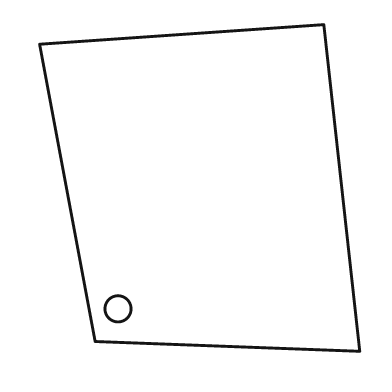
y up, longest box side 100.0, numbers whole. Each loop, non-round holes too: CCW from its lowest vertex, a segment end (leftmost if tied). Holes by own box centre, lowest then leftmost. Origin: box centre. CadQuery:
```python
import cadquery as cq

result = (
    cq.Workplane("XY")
    .moveTo(49.0, -50.0)
    .lineTo(38.0, 50.0)
    .lineTo(-49.0, 44.0)
    .lineTo(-32.0, -47.0)
    .close()
    .moveTo(-25.0, -37.0)
    .circle(4.0)
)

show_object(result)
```